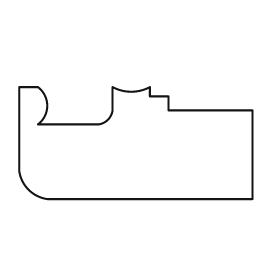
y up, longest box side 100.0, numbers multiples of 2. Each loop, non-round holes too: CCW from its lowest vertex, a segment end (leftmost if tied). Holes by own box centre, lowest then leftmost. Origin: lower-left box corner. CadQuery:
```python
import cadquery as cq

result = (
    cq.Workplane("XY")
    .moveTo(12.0, 0.0)
    .lineTo(100.0, 0.0)
    .lineTo(100.0, 38.0)
    .lineTo(64.0, 38.0)
    .lineTo(64.0, 44.0)
    .lineTo(56.0, 44.0)
    .lineTo(56.0, 48.0)
    .threePointArc((48.0, 46.0), (40.0, 48.0))
    .lineTo(40.0, 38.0)
    .threePointArc((38.0, 34.0), (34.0, 32.0))
    .lineTo(8.0, 32.0)
    .threePointArc((12.0, 40.0), (8.0, 48.0))
    .lineTo(0.0, 48.0)
    .lineTo(0.0, 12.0)
    .threePointArc((4.0, 4.0), (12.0, 0.0))
    .close()
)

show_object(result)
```